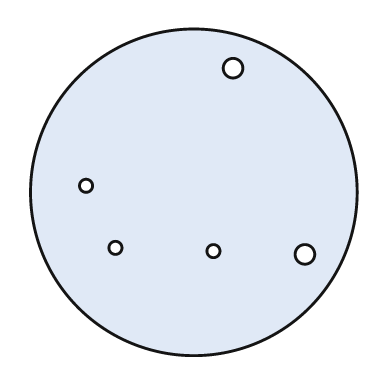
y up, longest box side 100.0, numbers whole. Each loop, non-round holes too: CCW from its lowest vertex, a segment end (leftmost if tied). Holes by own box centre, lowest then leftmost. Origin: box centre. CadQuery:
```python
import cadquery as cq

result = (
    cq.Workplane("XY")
    .moveTo(0.0, 0.0)
    .circle(50.0)
    .moveTo(34.0, -19.0)
    .circle(3.0)
    .moveTo(6.0, -18.0)
    .circle(2.0)
    .moveTo(-24.0, -17.0)
    .circle(2.0)
    .moveTo(-33.0, 2.0)
    .circle(2.0)
    .moveTo(12.0, 38.0)
    .circle(3.0)
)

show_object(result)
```